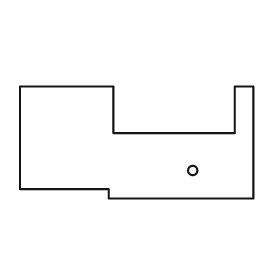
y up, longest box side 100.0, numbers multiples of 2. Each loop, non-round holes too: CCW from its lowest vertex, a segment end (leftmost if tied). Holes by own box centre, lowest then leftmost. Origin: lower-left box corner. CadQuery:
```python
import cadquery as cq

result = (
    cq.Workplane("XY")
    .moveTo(38.0, 0.0)
    .lineTo(100.0, 0.0)
    .lineTo(100.0, 48.0)
    .lineTo(92.0, 48.0)
    .lineTo(92.0, 28.0)
    .lineTo(40.0, 28.0)
    .lineTo(40.0, 48.0)
    .lineTo(0.0, 48.0)
    .lineTo(0.0, 4.0)
    .lineTo(38.0, 4.0)
    .close()
    .moveTo(74.0, 12.0)
    .circle(2.0)
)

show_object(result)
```